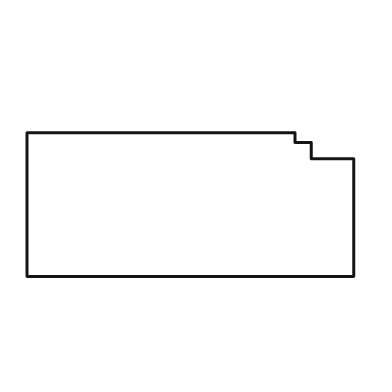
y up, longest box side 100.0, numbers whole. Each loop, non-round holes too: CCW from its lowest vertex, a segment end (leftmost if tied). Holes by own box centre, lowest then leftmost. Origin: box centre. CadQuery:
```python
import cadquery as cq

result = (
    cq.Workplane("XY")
    .moveTo(-50.0, -22.0)
    .lineTo(50.0, -22.0)
    .lineTo(50.0, 14.0)
    .lineTo(37.0, 14.0)
    .lineTo(37.0, 19.0)
    .lineTo(32.0, 19.0)
    .lineTo(32.0, 22.0)
    .lineTo(-50.0, 22.0)
    .close()
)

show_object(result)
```